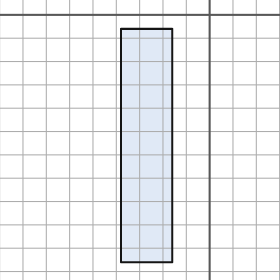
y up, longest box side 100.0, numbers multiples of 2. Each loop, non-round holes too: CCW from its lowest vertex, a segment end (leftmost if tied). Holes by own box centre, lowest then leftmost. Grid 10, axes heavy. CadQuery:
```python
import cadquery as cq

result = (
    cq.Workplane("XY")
    .moveTo(-38.0, -106.0)
    .lineTo(-16.0, -106.0)
    .lineTo(-16.0, -6.0)
    .lineTo(-38.0, -6.0)
    .close()
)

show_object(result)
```